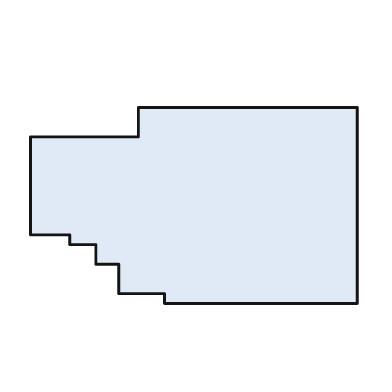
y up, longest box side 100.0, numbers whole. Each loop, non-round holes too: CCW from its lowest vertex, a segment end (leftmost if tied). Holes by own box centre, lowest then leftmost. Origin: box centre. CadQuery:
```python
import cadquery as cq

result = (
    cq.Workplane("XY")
    .moveTo(-9.0, -30.0)
    .lineTo(50.0, -30.0)
    .lineTo(50.0, 30.0)
    .lineTo(-17.0, 30.0)
    .lineTo(-17.0, 21.0)
    .lineTo(-50.0, 21.0)
    .lineTo(-50.0, -9.0)
    .lineTo(-38.0, -9.0)
    .lineTo(-38.0, -12.0)
    .lineTo(-30.0, -12.0)
    .lineTo(-30.0, -18.0)
    .lineTo(-23.0, -18.0)
    .lineTo(-23.0, -27.0)
    .lineTo(-9.0, -27.0)
    .close()
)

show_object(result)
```